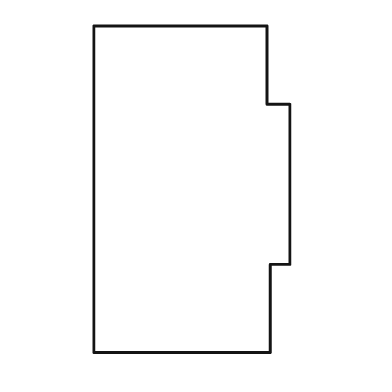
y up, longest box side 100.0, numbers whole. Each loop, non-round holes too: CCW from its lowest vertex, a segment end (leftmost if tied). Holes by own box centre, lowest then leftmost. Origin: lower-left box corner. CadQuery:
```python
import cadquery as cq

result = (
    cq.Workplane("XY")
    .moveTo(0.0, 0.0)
    .lineTo(54.0, 0.0)
    .lineTo(54.0, 27.0)
    .lineTo(60.0, 27.0)
    .lineTo(60.0, 76.0)
    .lineTo(53.0, 76.0)
    .lineTo(53.0, 100.0)
    .lineTo(0.0, 100.0)
    .close()
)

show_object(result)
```